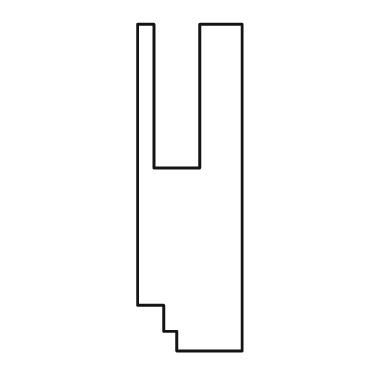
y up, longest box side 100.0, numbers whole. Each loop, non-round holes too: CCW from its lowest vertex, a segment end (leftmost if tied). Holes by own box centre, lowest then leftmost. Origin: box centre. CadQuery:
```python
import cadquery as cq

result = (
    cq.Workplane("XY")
    .moveTo(-4.0, -50.0)
    .lineTo(16.0, -50.0)
    .lineTo(16.0, 50.0)
    .lineTo(3.0, 50.0)
    .lineTo(3.0, 6.0)
    .lineTo(-11.0, 6.0)
    .lineTo(-11.0, 50.0)
    .lineTo(-16.0, 50.0)
    .lineTo(-16.0, -36.0)
    .lineTo(-8.0, -36.0)
    .lineTo(-8.0, -44.0)
    .lineTo(-4.0, -44.0)
    .close()
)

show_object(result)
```